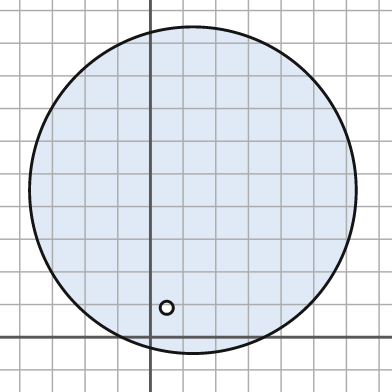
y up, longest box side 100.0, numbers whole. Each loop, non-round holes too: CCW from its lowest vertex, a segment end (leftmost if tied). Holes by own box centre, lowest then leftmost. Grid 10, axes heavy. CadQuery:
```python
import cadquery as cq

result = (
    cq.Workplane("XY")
    .moveTo(13.0, 45.0)
    .circle(50.0)
    .moveTo(5.0, 9.0)
    .circle(2.0)
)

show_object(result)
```